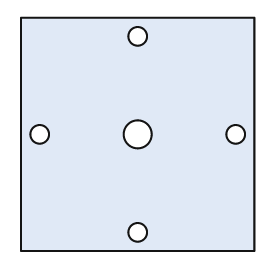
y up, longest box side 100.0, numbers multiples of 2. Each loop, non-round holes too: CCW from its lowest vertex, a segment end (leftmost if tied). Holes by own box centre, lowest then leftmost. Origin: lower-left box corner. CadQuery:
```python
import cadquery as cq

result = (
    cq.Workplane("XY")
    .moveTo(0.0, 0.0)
    .lineTo(100.0, 0.0)
    .lineTo(100.0, 100.0)
    .lineTo(0.0, 100.0)
    .close()
    .moveTo(50.0, 8.0)
    .circle(4.0)
    .moveTo(8.0, 50.0)
    .circle(4.0)
    .moveTo(50.0, 50.0)
    .circle(6.0)
    .moveTo(92.0, 50.0)
    .circle(4.0)
    .moveTo(50.0, 92.0)
    .circle(4.0)
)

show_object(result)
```